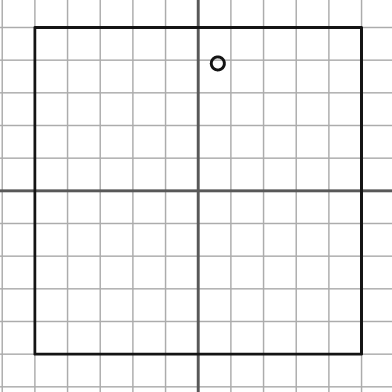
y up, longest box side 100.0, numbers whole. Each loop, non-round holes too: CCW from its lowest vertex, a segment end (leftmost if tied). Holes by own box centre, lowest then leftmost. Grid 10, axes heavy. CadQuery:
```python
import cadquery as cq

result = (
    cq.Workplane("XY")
    .moveTo(-50.0, -50.0)
    .lineTo(50.0, -50.0)
    .lineTo(50.0, 50.0)
    .lineTo(-50.0, 50.0)
    .close()
    .moveTo(6.0, 39.0)
    .circle(2.0)
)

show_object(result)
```